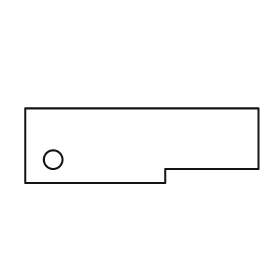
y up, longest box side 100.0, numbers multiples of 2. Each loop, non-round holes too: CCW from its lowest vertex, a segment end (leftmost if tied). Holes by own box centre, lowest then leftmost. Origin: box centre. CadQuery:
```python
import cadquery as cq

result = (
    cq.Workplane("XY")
    .moveTo(-50.0, -16.0)
    .lineTo(10.0, -16.0)
    .lineTo(10.0, -10.0)
    .lineTo(50.0, -10.0)
    .lineTo(50.0, 16.0)
    .lineTo(-50.0, 16.0)
    .close()
    .moveTo(-38.0, -6.0)
    .circle(4.0)
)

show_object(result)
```